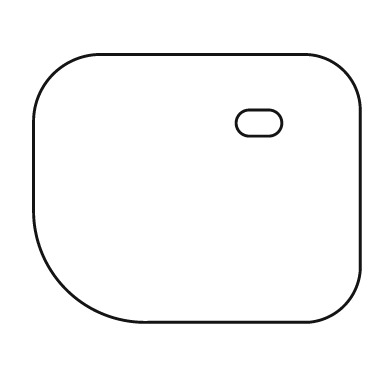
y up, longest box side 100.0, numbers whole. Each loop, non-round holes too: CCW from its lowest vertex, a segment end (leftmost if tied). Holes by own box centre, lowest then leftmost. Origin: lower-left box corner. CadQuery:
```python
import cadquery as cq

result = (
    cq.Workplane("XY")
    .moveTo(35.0, 0.0)
    .lineTo(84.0, 0.0)
    .threePointArc((95.0, 5.0), (100.0, 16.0))
    .lineTo(100.0, 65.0)
    .threePointArc((95.0, 77.0), (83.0, 82.0))
    .lineTo(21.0, 82.0)
    .threePointArc((6.0, 76.0), (0.0, 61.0))
    .lineTo(0.0, 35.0)
    .threePointArc((10.0, 10.0), (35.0, 0.0))
    .close()
    .moveTo(66.0, 57.0)
    .lineTo(72.0, 57.0)
    .threePointArc((76.0, 61.0), (72.0, 65.0))
    .lineTo(66.0, 65.0)
    .threePointArc((62.0, 61.0), (66.0, 57.0))
    .close()
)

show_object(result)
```